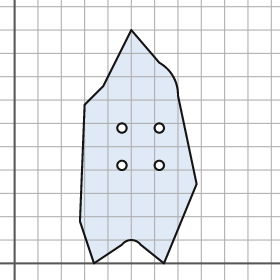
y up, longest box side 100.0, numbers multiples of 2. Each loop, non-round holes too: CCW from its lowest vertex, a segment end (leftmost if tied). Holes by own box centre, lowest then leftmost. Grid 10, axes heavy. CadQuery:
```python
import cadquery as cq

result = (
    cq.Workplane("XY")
    .moveTo(34.0, 0.0)
    .lineTo(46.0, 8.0)
    .threePointArc((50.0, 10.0), (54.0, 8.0))
    .lineTo(64.0, 0.0)
    .lineTo(78.0, 34.0)
    .lineTo(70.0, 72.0)
    .threePointArc((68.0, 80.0), (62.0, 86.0))
    .lineTo(50.0, 100.0)
    .lineTo(38.0, 76.0)
    .lineTo(30.0, 68.0)
    .lineTo(28.0, 18.0)
    .close()
    .moveTo(46.0, 42.0)
    .circle(2.0)
    .moveTo(62.0, 42.0)
    .circle(2.0)
    .moveTo(46.0, 58.0)
    .circle(2.0)
    .moveTo(62.0, 58.0)
    .circle(2.0)
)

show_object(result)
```